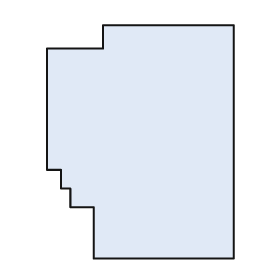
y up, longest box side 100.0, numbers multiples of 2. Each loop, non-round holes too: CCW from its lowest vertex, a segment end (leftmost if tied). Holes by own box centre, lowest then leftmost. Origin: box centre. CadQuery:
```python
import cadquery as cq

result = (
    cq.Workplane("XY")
    .moveTo(-20.0, -50.0)
    .lineTo(40.0, -50.0)
    .lineTo(40.0, 50.0)
    .lineTo(-16.0, 50.0)
    .lineTo(-16.0, 40.0)
    .lineTo(-40.0, 40.0)
    .lineTo(-40.0, -12.0)
    .lineTo(-34.0, -12.0)
    .lineTo(-34.0, -20.0)
    .lineTo(-30.0, -20.0)
    .lineTo(-30.0, -28.0)
    .lineTo(-20.0, -28.0)
    .close()
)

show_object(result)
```